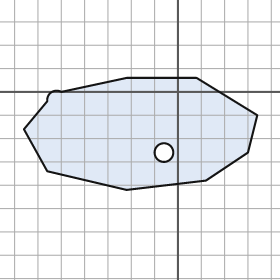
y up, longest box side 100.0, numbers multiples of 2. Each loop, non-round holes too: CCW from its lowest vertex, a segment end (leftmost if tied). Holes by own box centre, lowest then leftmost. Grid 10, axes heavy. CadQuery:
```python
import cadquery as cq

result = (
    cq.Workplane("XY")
    .moveTo(-22.0, -42.0)
    .lineTo(12.0, -38.0)
    .lineTo(30.0, -26.0)
    .lineTo(34.0, -10.0)
    .lineTo(8.0, 6.0)
    .lineTo(-22.0, 6.0)
    .lineTo(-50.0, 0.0)
    .threePointArc((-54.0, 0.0), (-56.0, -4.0))
    .lineTo(-66.0, -16.0)
    .lineTo(-56.0, -34.0)
    .close()
    .moveTo(-6.0, -26.0)
    .circle(4.0)
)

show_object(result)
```